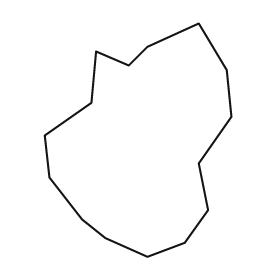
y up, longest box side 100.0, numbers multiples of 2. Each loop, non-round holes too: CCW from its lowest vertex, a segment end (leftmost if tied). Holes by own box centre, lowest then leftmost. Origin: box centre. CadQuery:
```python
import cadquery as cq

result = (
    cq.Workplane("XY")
    .moveTo(4.0, -50.0)
    .lineTo(20.0, -44.0)
    .lineTo(30.0, -30.0)
    .lineTo(26.0, -10.0)
    .lineTo(40.0, 10.0)
    .lineTo(38.0, 30.0)
    .lineTo(26.0, 50.0)
    .lineTo(4.0, 40.0)
    .lineTo(-4.0, 32.0)
    .lineTo(-18.0, 38.0)
    .lineTo(-20.0, 16.0)
    .lineTo(-40.0, 2.0)
    .lineTo(-38.0, -16.0)
    .lineTo(-24.0, -34.0)
    .lineTo(-14.0, -42.0)
    .close()
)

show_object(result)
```